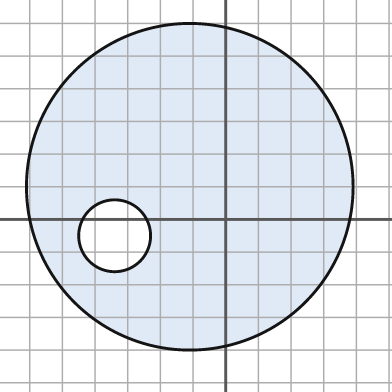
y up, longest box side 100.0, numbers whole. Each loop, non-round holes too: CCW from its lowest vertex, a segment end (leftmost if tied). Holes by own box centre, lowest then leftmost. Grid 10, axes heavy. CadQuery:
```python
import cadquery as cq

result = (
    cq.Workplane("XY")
    .moveTo(-11.0, 10.0)
    .circle(50.0)
    .moveTo(-34.0, -5.0)
    .circle(11.0)
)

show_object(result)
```